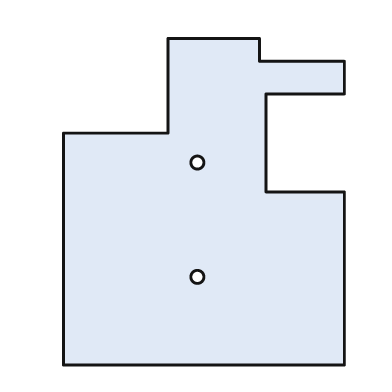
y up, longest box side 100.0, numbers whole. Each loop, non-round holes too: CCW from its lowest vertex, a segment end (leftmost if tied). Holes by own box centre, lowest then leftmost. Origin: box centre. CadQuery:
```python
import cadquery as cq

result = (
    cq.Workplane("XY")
    .moveTo(-43.0, -50.0)
    .lineTo(43.0, -50.0)
    .lineTo(43.0, 3.0)
    .lineTo(19.0, 3.0)
    .lineTo(19.0, 33.0)
    .lineTo(43.0, 33.0)
    .lineTo(43.0, 43.0)
    .lineTo(17.0, 43.0)
    .lineTo(17.0, 50.0)
    .lineTo(-11.0, 50.0)
    .lineTo(-11.0, 21.0)
    .lineTo(-43.0, 21.0)
    .close()
    .moveTo(-2.0, -23.0)
    .circle(2.0)
    .moveTo(-2.0, 12.0)
    .circle(2.0)
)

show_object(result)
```